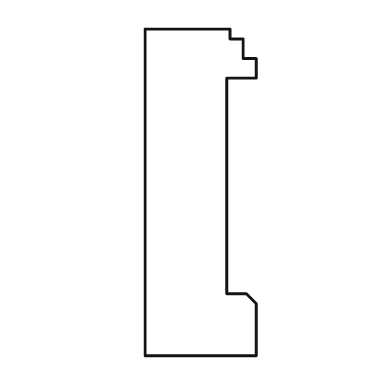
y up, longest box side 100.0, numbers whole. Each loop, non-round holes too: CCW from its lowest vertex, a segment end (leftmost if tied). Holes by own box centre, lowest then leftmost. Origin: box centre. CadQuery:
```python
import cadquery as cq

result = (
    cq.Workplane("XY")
    .moveTo(-17.0, -50.0)
    .lineTo(17.0, -50.0)
    .lineTo(17.0, -34.0)
    .lineTo(14.0, -31.0)
    .lineTo(8.0, -31.0)
    .lineTo(8.0, 35.0)
    .lineTo(17.0, 35.0)
    .lineTo(17.0, 41.0)
    .lineTo(13.0, 41.0)
    .lineTo(13.0, 47.0)
    .lineTo(9.0, 47.0)
    .lineTo(9.0, 50.0)
    .lineTo(-17.0, 50.0)
    .close()
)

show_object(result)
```